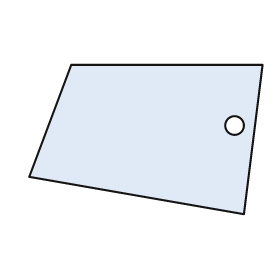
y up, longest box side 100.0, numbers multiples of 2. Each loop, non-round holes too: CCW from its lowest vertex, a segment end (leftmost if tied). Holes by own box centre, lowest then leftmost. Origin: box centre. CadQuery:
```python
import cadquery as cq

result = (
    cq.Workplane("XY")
    .moveTo(42.0, -32.0)
    .lineTo(50.0, 32.0)
    .lineTo(-32.0, 32.0)
    .lineTo(-50.0, -16.0)
    .close()
    .moveTo(38.0, 6.0)
    .circle(4.0)
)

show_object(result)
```